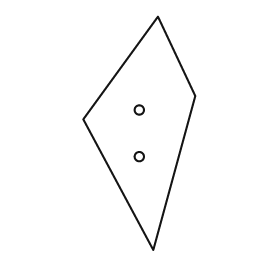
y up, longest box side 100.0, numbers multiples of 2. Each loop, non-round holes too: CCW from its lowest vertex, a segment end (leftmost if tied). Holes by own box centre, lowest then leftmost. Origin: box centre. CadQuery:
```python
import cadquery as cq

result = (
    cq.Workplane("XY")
    .moveTo(6.0, -50.0)
    .lineTo(24.0, 16.0)
    .lineTo(8.0, 50.0)
    .lineTo(-24.0, 6.0)
    .close()
    .moveTo(0.0, -10.0)
    .circle(2.0)
    .moveTo(0.0, 10.0)
    .circle(2.0)
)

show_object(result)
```